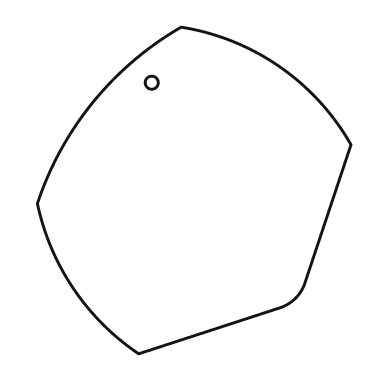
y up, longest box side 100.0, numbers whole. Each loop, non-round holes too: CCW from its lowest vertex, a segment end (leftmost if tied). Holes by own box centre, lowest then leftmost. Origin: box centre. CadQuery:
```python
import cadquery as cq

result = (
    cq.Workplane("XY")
    .moveTo(-17.0, -50.0)
    .lineTo(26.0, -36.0)
    .threePointArc((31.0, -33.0), (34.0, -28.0))
    .lineTo(48.0, 14.0)
    .threePointArc((26.0, 38.0), (-4.0, 50.0))
    .threePointArc((-31.0, 27.0), (-48.0, -4.0))
    .threePointArc((-37.0, -30.0), (-17.0, -50.0))
    .close()
    .moveTo(-13.0, 33.0)
    .circle(2.0)
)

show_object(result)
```